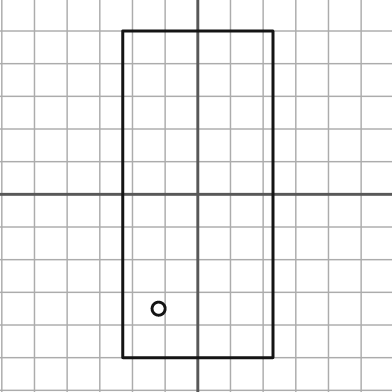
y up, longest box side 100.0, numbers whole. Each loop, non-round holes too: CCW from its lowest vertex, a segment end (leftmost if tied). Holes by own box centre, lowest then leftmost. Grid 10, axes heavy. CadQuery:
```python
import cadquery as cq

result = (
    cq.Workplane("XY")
    .moveTo(-23.0, -50.0)
    .lineTo(23.0, -50.0)
    .lineTo(23.0, 50.0)
    .lineTo(-23.0, 50.0)
    .close()
    .moveTo(-12.0, -35.0)
    .circle(2.0)
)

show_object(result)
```